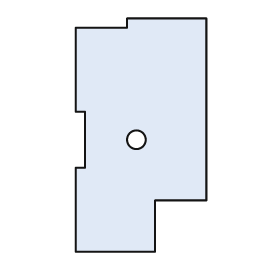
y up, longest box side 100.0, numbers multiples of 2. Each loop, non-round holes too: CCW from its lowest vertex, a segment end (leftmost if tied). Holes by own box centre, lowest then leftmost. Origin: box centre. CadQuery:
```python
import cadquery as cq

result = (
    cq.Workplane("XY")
    .moveTo(-28.0, -50.0)
    .lineTo(6.0, -50.0)
    .lineTo(6.0, -28.0)
    .lineTo(28.0, -28.0)
    .lineTo(28.0, 50.0)
    .lineTo(-6.0, 50.0)
    .lineTo(-6.0, 46.0)
    .lineTo(-28.0, 46.0)
    .lineTo(-28.0, 10.0)
    .lineTo(-24.0, 10.0)
    .lineTo(-24.0, -14.0)
    .lineTo(-28.0, -14.0)
    .close()
    .moveTo(-2.0, -2.0)
    .circle(4.0)
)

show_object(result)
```